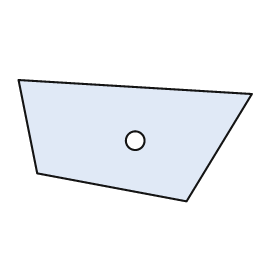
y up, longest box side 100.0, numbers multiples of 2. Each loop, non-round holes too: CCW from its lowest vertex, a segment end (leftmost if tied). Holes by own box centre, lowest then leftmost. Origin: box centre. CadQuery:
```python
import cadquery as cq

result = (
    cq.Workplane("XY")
    .moveTo(22.0, -26.0)
    .lineTo(50.0, 20.0)
    .lineTo(-50.0, 26.0)
    .lineTo(-42.0, -14.0)
    .close()
    .moveTo(0.0, 0.0)
    .circle(4.0)
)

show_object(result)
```